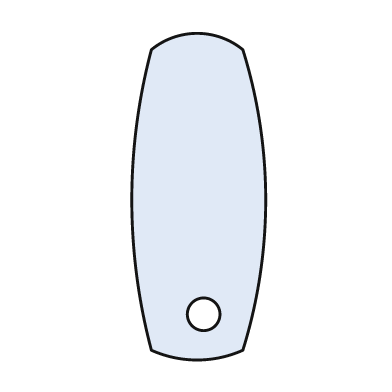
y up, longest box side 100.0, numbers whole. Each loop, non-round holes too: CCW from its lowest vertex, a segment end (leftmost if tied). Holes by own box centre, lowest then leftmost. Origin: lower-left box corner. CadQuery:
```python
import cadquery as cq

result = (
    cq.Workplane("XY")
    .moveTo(6.0, 3.0)
    .threePointArc((20.0, 0.0), (34.0, 3.0))
    .threePointArc((41.0, 49.0), (34.0, 95.0))
    .threePointArc((20.0, 100.0), (6.0, 95.0))
    .threePointArc((0.0, 49.0), (6.0, 3.0))
    .close()
    .moveTo(22.0, 14.0)
    .circle(5.0)
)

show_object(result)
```